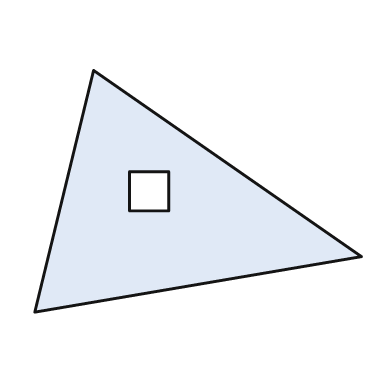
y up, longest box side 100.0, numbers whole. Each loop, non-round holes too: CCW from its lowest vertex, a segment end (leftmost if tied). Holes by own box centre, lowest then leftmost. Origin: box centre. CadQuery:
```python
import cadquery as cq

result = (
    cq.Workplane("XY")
    .moveTo(-50.0, -37.0)
    .lineTo(50.0, -20.0)
    .lineTo(-32.0, 37.0)
    .close()
    .moveTo(-21.0, -6.0)
    .lineTo(-9.0, -6.0)
    .lineTo(-9.0, 6.0)
    .lineTo(-21.0, 6.0)
    .close()
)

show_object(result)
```